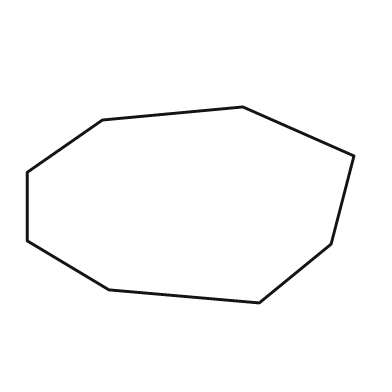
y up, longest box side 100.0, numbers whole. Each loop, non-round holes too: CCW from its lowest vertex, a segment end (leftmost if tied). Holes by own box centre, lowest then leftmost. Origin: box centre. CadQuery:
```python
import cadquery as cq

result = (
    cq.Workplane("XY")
    .moveTo(21.0, -30.0)
    .lineTo(43.0, -12.0)
    .lineTo(50.0, 15.0)
    .lineTo(16.0, 30.0)
    .lineTo(-27.0, 26.0)
    .lineTo(-50.0, 10.0)
    .lineTo(-50.0, -11.0)
    .lineTo(-25.0, -26.0)
    .close()
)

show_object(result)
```